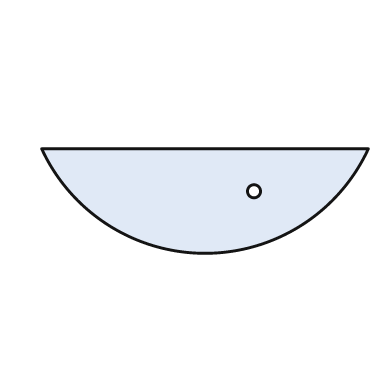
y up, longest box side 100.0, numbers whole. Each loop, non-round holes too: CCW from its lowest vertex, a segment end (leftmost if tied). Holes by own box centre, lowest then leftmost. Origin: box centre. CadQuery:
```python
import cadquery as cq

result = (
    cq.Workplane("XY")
    .moveTo(-50.0, 16.0)
    .threePointArc((0.0, -16.0), (50.0, 16.0))
    .close()
    .moveTo(15.0, 3.0)
    .circle(2.0)
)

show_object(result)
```